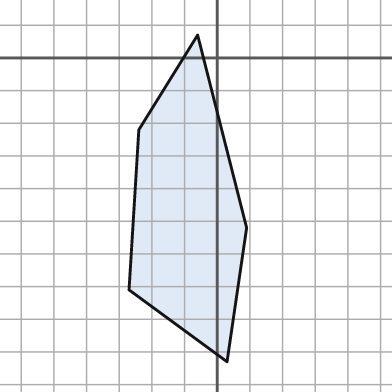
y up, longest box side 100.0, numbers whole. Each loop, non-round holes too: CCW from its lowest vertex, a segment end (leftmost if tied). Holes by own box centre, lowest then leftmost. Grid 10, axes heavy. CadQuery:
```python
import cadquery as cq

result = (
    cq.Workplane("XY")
    .moveTo(3.0, -93.0)
    .lineTo(9.0, -52.0)
    .lineTo(-6.0, 7.0)
    .lineTo(-24.0, -22.0)
    .lineTo(-27.0, -71.0)
    .close()
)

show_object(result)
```